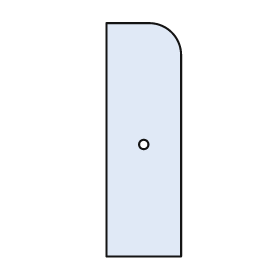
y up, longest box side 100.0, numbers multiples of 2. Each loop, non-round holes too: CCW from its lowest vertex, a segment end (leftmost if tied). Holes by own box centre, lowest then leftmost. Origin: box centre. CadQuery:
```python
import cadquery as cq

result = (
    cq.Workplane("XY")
    .moveTo(-16.0, -50.0)
    .lineTo(16.0, -50.0)
    .lineTo(16.0, 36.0)
    .threePointArc((12.0, 46.0), (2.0, 50.0))
    .lineTo(-16.0, 50.0)
    .close()
    .moveTo(0.0, -2.0)
    .circle(2.0)
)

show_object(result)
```